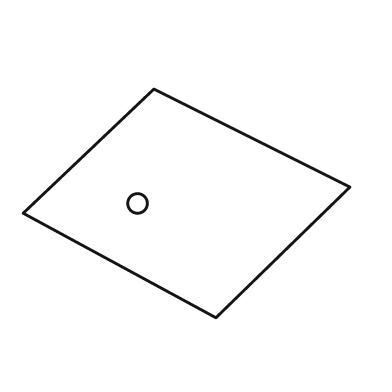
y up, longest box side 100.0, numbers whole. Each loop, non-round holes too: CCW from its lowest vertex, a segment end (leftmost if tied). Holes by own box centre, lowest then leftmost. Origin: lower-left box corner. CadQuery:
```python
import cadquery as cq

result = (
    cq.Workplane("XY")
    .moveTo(59.0, 0.0)
    .lineTo(100.0, 40.0)
    .lineTo(40.0, 70.0)
    .lineTo(0.0, 32.0)
    .close()
    .moveTo(35.0, 35.0)
    .circle(3.0)
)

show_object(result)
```